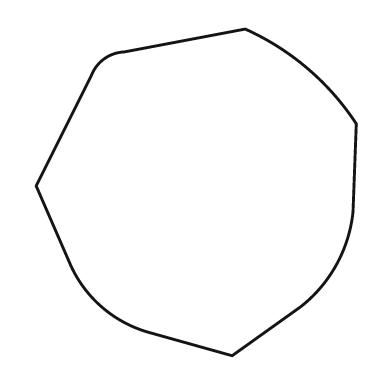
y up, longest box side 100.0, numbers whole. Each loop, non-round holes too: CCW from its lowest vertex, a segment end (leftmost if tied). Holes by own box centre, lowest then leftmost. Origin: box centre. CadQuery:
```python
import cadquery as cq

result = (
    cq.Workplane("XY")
    .moveTo(11.0, -50.0)
    .lineTo(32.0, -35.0)
    .threePointArc((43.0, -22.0), (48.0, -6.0))
    .lineTo(49.0, 21.0)
    .threePointArc((34.0, 38.0), (15.0, 50.0))
    .lineTo(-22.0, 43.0)
    .threePointArc((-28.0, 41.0), (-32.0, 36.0))
    .lineTo(-49.0, 2.0)
    .lineTo(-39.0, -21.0)
    .threePointArc((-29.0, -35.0), (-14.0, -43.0))
    .close()
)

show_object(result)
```